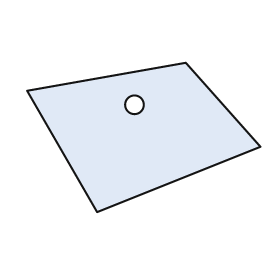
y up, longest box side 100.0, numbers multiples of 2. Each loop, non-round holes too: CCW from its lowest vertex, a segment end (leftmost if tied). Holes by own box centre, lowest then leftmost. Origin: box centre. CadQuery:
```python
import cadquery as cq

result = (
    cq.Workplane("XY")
    .moveTo(-20.0, -32.0)
    .lineTo(50.0, -4.0)
    .lineTo(18.0, 32.0)
    .lineTo(-50.0, 20.0)
    .close()
    .moveTo(-4.0, 14.0)
    .circle(4.0)
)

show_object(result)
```